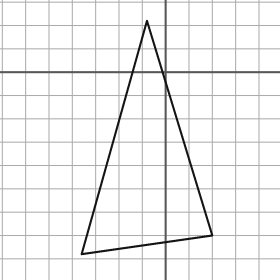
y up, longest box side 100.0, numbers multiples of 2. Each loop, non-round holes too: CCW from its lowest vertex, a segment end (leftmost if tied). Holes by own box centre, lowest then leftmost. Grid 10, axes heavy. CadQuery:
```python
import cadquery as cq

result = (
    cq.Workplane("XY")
    .moveTo(-36.0, -78.0)
    .lineTo(20.0, -70.0)
    .lineTo(-8.0, 22.0)
    .close()
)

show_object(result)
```